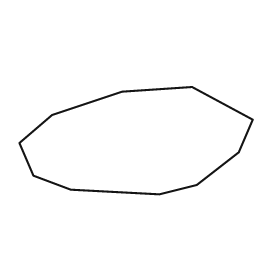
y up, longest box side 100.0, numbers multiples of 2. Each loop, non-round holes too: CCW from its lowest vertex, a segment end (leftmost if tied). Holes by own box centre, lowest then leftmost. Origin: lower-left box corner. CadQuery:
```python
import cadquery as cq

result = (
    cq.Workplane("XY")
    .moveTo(60.0, 0.0)
    .lineTo(76.0, 4.0)
    .lineTo(94.0, 18.0)
    .lineTo(100.0, 32.0)
    .lineTo(74.0, 46.0)
    .lineTo(44.0, 44.0)
    .lineTo(14.0, 34.0)
    .lineTo(0.0, 22.0)
    .lineTo(6.0, 8.0)
    .lineTo(22.0, 2.0)
    .close()
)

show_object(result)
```